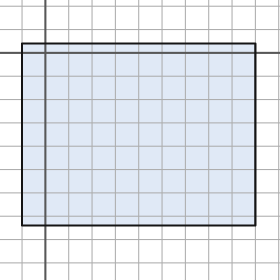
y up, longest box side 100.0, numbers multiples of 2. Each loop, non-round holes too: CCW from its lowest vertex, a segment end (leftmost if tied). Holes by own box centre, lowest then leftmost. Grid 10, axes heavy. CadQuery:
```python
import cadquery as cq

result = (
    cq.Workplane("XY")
    .moveTo(-10.0, -74.0)
    .lineTo(90.0, -74.0)
    .lineTo(90.0, 4.0)
    .lineTo(-10.0, 4.0)
    .close()
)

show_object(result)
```